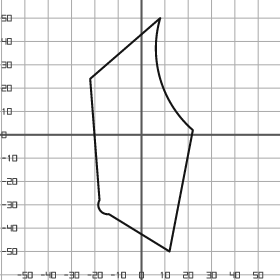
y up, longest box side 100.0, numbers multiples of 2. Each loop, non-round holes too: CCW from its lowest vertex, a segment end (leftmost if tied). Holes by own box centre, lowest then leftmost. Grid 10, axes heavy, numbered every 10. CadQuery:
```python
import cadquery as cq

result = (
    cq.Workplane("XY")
    .moveTo(12.0, -50.0)
    .lineTo(22.0, 2.0)
    .threePointArc((8.0, 24.0), (8.0, 50.0))
    .lineTo(-22.0, 24.0)
    .lineTo(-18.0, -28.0)
    .threePointArc((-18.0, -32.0), (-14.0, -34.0))
    .close()
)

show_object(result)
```